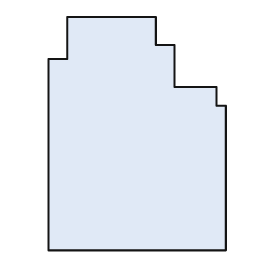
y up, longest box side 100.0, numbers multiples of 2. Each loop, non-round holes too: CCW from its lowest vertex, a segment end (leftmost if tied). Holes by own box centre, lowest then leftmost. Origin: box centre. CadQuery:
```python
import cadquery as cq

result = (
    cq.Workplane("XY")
    .moveTo(-38.0, -50.0)
    .lineTo(38.0, -50.0)
    .lineTo(38.0, 12.0)
    .lineTo(34.0, 12.0)
    .lineTo(34.0, 20.0)
    .lineTo(16.0, 20.0)
    .lineTo(16.0, 38.0)
    .lineTo(8.0, 38.0)
    .lineTo(8.0, 50.0)
    .lineTo(-30.0, 50.0)
    .lineTo(-30.0, 32.0)
    .lineTo(-38.0, 32.0)
    .close()
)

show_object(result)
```